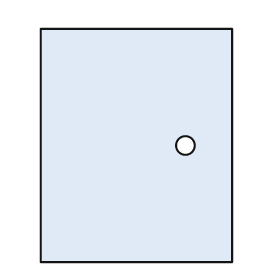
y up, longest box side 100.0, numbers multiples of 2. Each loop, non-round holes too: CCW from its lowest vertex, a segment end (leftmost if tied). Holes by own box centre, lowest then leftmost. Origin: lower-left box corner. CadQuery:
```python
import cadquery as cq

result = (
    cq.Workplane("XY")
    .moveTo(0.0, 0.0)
    .lineTo(82.0, 0.0)
    .lineTo(82.0, 100.0)
    .lineTo(0.0, 100.0)
    .close()
    .moveTo(62.0, 50.0)
    .circle(4.0)
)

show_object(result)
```